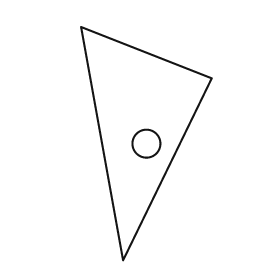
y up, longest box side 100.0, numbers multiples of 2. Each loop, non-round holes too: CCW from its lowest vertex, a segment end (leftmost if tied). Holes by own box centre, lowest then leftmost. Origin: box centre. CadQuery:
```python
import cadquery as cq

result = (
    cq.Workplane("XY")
    .moveTo(-10.0, -50.0)
    .lineTo(28.0, 28.0)
    .lineTo(-28.0, 50.0)
    .close()
    .moveTo(0.0, 0.0)
    .circle(6.0)
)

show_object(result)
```